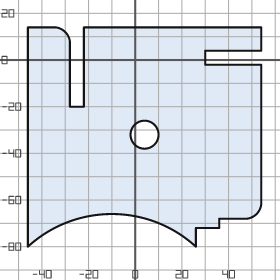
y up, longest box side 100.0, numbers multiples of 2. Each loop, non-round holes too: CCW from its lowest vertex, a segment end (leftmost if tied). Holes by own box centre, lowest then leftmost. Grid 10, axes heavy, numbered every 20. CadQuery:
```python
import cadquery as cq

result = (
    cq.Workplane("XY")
    .moveTo(-46.0, -80.0)
    .threePointArc((-10.0, -66.0), (26.0, -80.0))
    .lineTo(26.0, -72.0)
    .lineTo(36.0, -72.0)
    .lineTo(36.0, -68.0)
    .lineTo(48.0, -68.0)
    .threePointArc((52.0, -66.0), (54.0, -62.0))
    .lineTo(54.0, -2.0)
    .lineTo(30.0, -2.0)
    .lineTo(30.0, 4.0)
    .lineTo(54.0, 4.0)
    .lineTo(54.0, 14.0)
    .lineTo(-22.0, 14.0)
    .lineTo(-22.0, -20.0)
    .lineTo(-28.0, -20.0)
    .lineTo(-28.0, 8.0)
    .threePointArc((-30.0, 12.0), (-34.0, 14.0))
    .lineTo(-46.0, 14.0)
    .close()
    .moveTo(4.0, -32.0)
    .circle(6.0)
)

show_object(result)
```